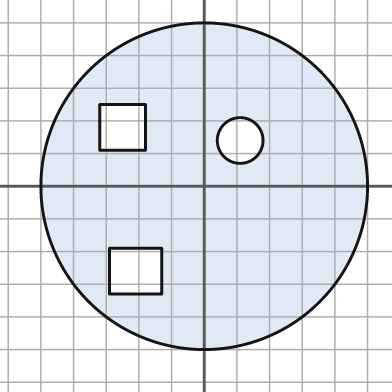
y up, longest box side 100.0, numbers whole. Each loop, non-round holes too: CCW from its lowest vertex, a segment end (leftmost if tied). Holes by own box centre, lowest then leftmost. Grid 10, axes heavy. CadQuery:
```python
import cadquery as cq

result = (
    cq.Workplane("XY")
    .moveTo(0.0, 0.0)
    .circle(50.0)
    .moveTo(-29.0, -33.0)
    .lineTo(-13.0, -33.0)
    .lineTo(-13.0, -19.0)
    .lineTo(-29.0, -19.0)
    .close()
    .moveTo(11.0, 14.0)
    .circle(7.0)
    .moveTo(-32.0, 11.0)
    .lineTo(-18.0, 11.0)
    .lineTo(-18.0, 25.0)
    .lineTo(-32.0, 25.0)
    .close()
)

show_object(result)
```